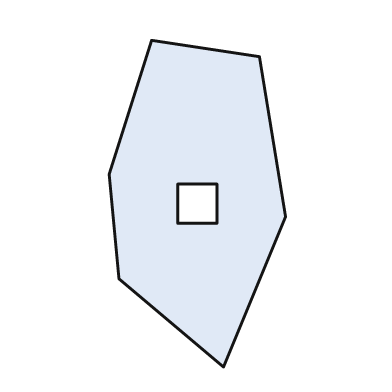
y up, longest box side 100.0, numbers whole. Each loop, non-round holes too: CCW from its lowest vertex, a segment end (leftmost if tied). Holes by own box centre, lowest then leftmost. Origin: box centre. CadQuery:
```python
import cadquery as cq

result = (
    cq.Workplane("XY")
    .moveTo(8.0, -50.0)
    .lineTo(27.0, -4.0)
    .lineTo(19.0, 45.0)
    .lineTo(-14.0, 50.0)
    .lineTo(-27.0, 9.0)
    .lineTo(-24.0, -23.0)
    .close()
    .moveTo(-6.0, -6.0)
    .lineTo(6.0, -6.0)
    .lineTo(6.0, 6.0)
    .lineTo(-6.0, 6.0)
    .close()
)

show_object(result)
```